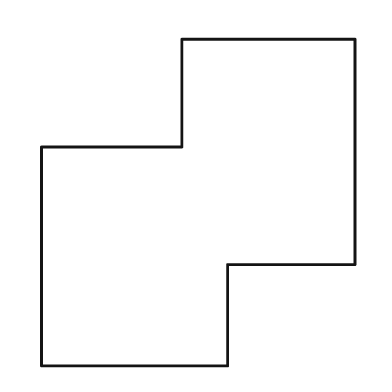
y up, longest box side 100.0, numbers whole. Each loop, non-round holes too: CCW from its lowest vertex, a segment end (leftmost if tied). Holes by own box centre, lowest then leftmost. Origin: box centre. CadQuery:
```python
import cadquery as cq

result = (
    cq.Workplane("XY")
    .moveTo(-48.0, -50.0)
    .lineTo(9.0, -50.0)
    .lineTo(9.0, -19.0)
    .lineTo(48.0, -19.0)
    .lineTo(48.0, 50.0)
    .lineTo(-5.0, 50.0)
    .lineTo(-5.0, 17.0)
    .lineTo(-48.0, 17.0)
    .close()
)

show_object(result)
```